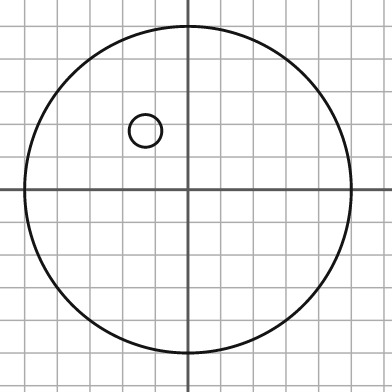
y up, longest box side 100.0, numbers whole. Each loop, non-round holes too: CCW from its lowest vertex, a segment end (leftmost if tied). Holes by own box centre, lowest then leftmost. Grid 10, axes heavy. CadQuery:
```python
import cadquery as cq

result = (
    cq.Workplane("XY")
    .moveTo(0.0, 0.0)
    .circle(50.0)
    .moveTo(-13.0, 18.0)
    .circle(5.0)
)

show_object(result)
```